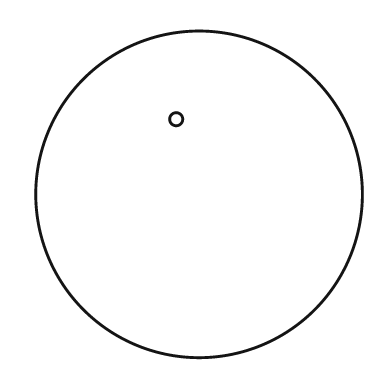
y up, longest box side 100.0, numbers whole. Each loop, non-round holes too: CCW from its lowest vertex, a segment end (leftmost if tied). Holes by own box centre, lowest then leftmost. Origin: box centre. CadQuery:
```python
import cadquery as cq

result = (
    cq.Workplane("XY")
    .moveTo(0.0, 0.0)
    .circle(50.0)
    .moveTo(-7.0, 23.0)
    .circle(2.0)
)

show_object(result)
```